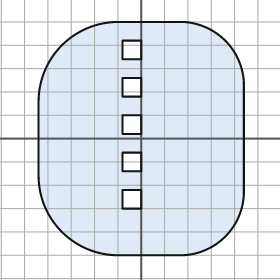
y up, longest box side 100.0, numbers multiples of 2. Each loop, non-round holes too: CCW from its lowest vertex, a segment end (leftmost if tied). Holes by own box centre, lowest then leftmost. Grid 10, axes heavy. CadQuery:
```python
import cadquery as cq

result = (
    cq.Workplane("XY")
    .moveTo(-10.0, -50.0)
    .lineTo(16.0, -50.0)
    .threePointArc((36.0, -42.0), (44.0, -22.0))
    .lineTo(44.0, 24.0)
    .threePointArc((36.0, 42.0), (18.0, 50.0))
    .lineTo(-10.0, 50.0)
    .threePointArc((-34.0, 40.0), (-44.0, 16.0))
    .lineTo(-44.0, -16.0)
    .threePointArc((-34.0, -40.0), (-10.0, -50.0))
    .close()
    .moveTo(-8.0, -30.0)
    .lineTo(0.0, -30.0)
    .lineTo(0.0, -22.0)
    .lineTo(-8.0, -22.0)
    .close()
    .moveTo(-8.0, -14.0)
    .lineTo(0.0, -14.0)
    .lineTo(0.0, -6.0)
    .lineTo(-8.0, -6.0)
    .close()
    .moveTo(-8.0, 2.0)
    .lineTo(0.0, 2.0)
    .lineTo(0.0, 10.0)
    .lineTo(-8.0, 10.0)
    .close()
    .moveTo(-8.0, 18.0)
    .lineTo(0.0, 18.0)
    .lineTo(0.0, 26.0)
    .lineTo(-8.0, 26.0)
    .close()
    .moveTo(-8.0, 34.0)
    .lineTo(0.0, 34.0)
    .lineTo(0.0, 42.0)
    .lineTo(-8.0, 42.0)
    .close()
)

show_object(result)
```